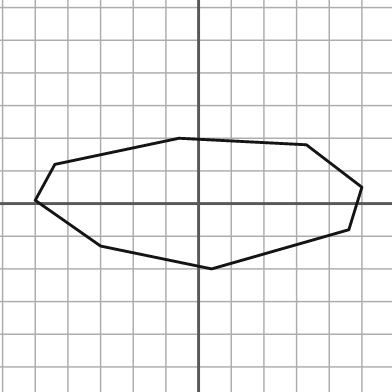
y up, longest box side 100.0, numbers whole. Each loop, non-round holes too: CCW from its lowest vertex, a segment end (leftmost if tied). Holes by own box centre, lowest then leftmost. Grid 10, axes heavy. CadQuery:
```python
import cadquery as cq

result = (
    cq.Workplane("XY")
    .moveTo(4.0, -20.0)
    .lineTo(46.0, -8.0)
    .lineTo(50.0, 5.0)
    .lineTo(33.0, 18.0)
    .lineTo(-6.0, 20.0)
    .lineTo(-44.0, 12.0)
    .lineTo(-50.0, 1.0)
    .lineTo(-30.0, -13.0)
    .close()
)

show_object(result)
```